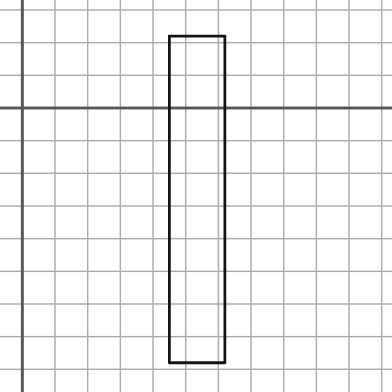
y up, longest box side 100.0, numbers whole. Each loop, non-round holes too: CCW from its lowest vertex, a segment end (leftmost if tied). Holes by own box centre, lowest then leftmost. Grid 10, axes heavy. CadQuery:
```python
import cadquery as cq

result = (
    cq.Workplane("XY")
    .moveTo(45.0, -78.0)
    .lineTo(62.0, -78.0)
    .lineTo(62.0, 22.0)
    .lineTo(45.0, 22.0)
    .close()
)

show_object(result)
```